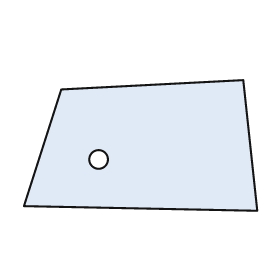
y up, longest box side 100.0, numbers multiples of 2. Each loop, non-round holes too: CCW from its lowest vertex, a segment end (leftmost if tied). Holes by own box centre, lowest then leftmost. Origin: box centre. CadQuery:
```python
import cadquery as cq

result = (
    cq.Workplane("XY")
    .moveTo(50.0, -28.0)
    .lineTo(44.0, 28.0)
    .lineTo(-34.0, 24.0)
    .lineTo(-50.0, -26.0)
    .close()
    .moveTo(-18.0, -6.0)
    .circle(4.0)
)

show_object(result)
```